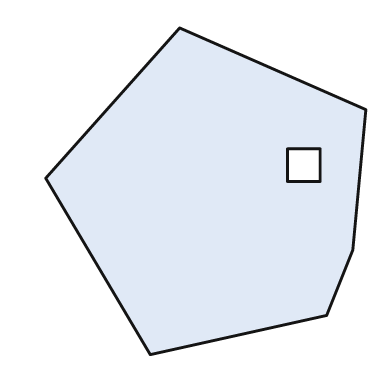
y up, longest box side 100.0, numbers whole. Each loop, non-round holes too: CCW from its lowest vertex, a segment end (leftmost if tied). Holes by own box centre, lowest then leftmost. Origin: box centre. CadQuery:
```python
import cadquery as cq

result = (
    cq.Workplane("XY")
    .moveTo(-17.0, -50.0)
    .lineTo(37.0, -38.0)
    .lineTo(45.0, -18.0)
    .lineTo(49.0, 25.0)
    .lineTo(-8.0, 50.0)
    .lineTo(-49.0, 4.0)
    .close()
    .moveTo(25.0, 3.0)
    .lineTo(35.0, 3.0)
    .lineTo(35.0, 13.0)
    .lineTo(25.0, 13.0)
    .close()
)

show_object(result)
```